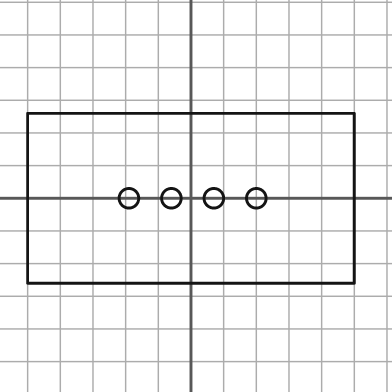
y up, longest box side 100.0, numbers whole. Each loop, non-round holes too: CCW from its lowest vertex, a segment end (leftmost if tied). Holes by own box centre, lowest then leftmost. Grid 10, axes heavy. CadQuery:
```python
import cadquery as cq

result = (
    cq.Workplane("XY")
    .moveTo(-50.0, -26.0)
    .lineTo(50.0, -26.0)
    .lineTo(50.0, 26.0)
    .lineTo(-50.0, 26.0)
    .close()
    .moveTo(-19.0, 0.0)
    .circle(3.0)
    .moveTo(-6.0, 0.0)
    .circle(3.0)
    .moveTo(7.0, 0.0)
    .circle(3.0)
    .moveTo(20.0, 0.0)
    .circle(3.0)
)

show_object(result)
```